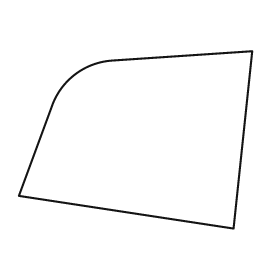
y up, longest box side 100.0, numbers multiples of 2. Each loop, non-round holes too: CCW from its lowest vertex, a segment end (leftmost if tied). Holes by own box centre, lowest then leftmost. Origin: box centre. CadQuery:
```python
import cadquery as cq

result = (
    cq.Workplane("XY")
    .moveTo(42.0, -38.0)
    .lineTo(50.0, 38.0)
    .lineTo(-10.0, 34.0)
    .threePointArc((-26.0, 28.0), (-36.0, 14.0))
    .lineTo(-50.0, -24.0)
    .close()
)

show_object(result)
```